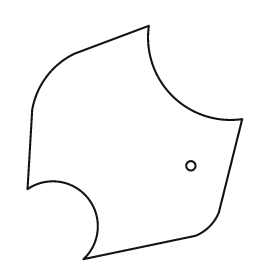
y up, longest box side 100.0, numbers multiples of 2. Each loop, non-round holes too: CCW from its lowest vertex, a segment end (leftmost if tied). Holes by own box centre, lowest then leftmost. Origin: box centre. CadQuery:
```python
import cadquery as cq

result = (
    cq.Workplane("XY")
    .moveTo(-22.0, -50.0)
    .lineTo(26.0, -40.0)
    .threePointArc((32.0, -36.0), (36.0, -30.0))
    .lineTo(46.0, 10.0)
    .threePointArc((16.0, 20.0), (6.0, 50.0))
    .lineTo(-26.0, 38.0)
    .threePointArc((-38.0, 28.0), (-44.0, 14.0))
    .lineTo(-46.0, -20.0)
    .threePointArc((-20.0, -24.0), (-22.0, -50.0))
    .close()
    .moveTo(24.0, -10.0)
    .circle(2.0)
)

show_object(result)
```